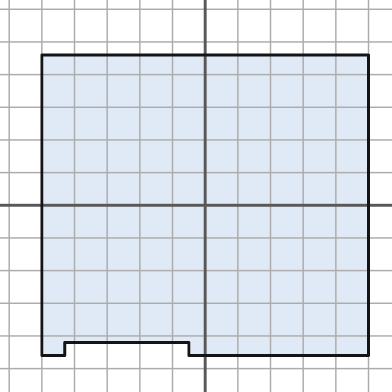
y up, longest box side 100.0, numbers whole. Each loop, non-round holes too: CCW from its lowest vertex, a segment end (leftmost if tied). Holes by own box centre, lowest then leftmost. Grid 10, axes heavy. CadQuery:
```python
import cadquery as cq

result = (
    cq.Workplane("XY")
    .moveTo(-50.0, -46.0)
    .lineTo(-43.0, -46.0)
    .lineTo(-43.0, -42.0)
    .lineTo(-5.0, -42.0)
    .lineTo(-5.0, -46.0)
    .lineTo(50.0, -46.0)
    .lineTo(50.0, 46.0)
    .lineTo(-50.0, 46.0)
    .close()
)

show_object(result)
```